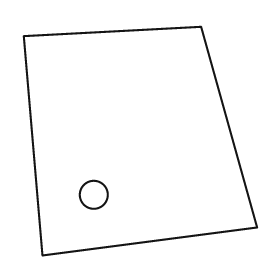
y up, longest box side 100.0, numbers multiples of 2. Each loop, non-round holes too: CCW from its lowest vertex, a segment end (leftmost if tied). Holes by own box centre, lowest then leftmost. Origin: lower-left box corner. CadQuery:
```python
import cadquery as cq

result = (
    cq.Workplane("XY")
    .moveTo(8.0, 0.0)
    .lineTo(100.0, 12.0)
    .lineTo(76.0, 98.0)
    .lineTo(0.0, 94.0)
    .close()
    .moveTo(30.0, 26.0)
    .circle(6.0)
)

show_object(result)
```